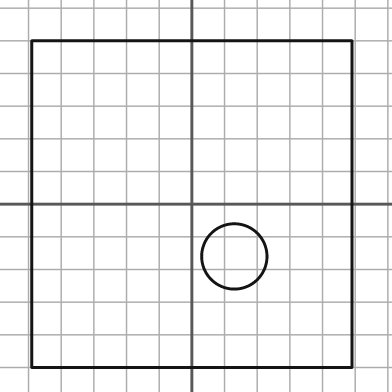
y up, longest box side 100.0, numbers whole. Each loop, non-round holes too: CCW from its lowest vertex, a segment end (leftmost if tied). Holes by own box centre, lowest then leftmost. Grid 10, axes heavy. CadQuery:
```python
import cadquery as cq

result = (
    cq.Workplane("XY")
    .moveTo(-49.0, -50.0)
    .lineTo(49.0, -50.0)
    .lineTo(49.0, 50.0)
    .lineTo(-49.0, 50.0)
    .close()
    .moveTo(13.0, -16.0)
    .circle(10.0)
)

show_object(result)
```